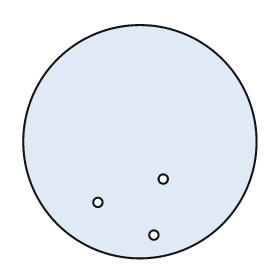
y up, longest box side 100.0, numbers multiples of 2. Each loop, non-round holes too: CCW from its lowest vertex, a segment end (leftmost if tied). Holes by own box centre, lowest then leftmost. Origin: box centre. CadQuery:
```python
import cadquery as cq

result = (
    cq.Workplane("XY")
    .moveTo(0.0, 0.0)
    .circle(50.0)
    .moveTo(6.0, -40.0)
    .circle(2.0)
    .moveTo(-18.0, -26.0)
    .circle(2.0)
    .moveTo(10.0, -16.0)
    .circle(2.0)
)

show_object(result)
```